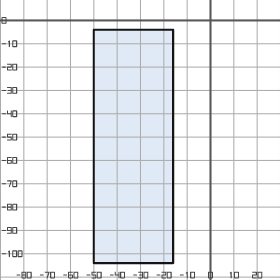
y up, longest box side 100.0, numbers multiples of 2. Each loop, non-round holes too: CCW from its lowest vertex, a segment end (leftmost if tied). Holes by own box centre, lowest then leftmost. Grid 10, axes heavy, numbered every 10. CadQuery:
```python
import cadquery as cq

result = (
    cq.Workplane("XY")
    .moveTo(-50.0, -104.0)
    .lineTo(-16.0, -104.0)
    .lineTo(-16.0, -4.0)
    .lineTo(-50.0, -4.0)
    .close()
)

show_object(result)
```